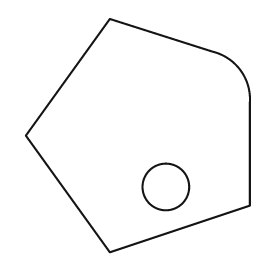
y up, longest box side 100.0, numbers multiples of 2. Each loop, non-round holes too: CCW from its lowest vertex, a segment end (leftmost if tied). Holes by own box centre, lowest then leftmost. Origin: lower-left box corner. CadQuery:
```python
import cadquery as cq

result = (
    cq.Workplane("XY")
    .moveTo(36.0, 0.0)
    .lineTo(96.0, 20.0)
    .lineTo(96.0, 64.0)
    .threePointArc((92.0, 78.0), (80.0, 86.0))
    .lineTo(36.0, 100.0)
    .lineTo(0.0, 50.0)
    .close()
    .moveTo(60.0, 28.0)
    .circle(10.0)
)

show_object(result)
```